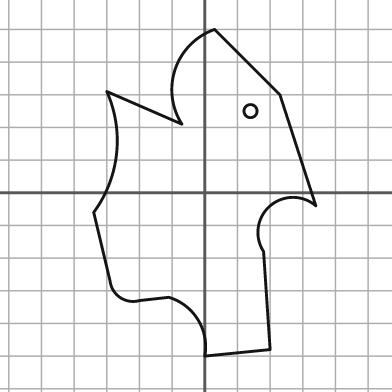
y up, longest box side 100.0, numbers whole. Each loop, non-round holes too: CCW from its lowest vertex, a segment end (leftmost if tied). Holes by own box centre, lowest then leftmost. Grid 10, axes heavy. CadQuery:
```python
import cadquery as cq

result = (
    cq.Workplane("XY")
    .moveTo(0.0, -50.0)
    .lineTo(20.0, -48.0)
    .lineTo(18.0, -18.0)
    .threePointArc((20.0, -4.0), (34.0, -4.0))
    .lineTo(23.0, 30.0)
    .lineTo(3.0, 50.0)
    .threePointArc((-9.0, 38.0), (-7.0, 21.0))
    .lineTo(-30.0, 31.0)
    .threePointArc((-27.0, 12.0), (-34.0, -6.0))
    .lineTo(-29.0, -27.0)
    .threePointArc((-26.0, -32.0), (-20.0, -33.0))
    .lineTo(-11.0, -32.0)
    .threePointArc((-2.0, -39.0), (0.0, -50.0))
    .close()
    .moveTo(14.0, 25.0)
    .circle(2.0)
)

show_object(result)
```